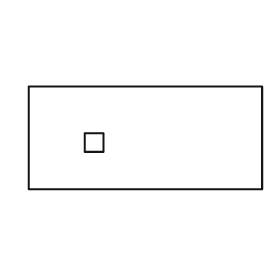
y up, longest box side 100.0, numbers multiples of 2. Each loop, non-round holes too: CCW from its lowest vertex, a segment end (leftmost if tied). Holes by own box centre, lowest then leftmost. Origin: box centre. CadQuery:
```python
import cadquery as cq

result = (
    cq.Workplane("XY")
    .moveTo(-50.0, -22.0)
    .lineTo(50.0, -22.0)
    .lineTo(50.0, 22.0)
    .lineTo(-50.0, 22.0)
    .close()
    .moveTo(-26.0, -6.0)
    .lineTo(-18.0, -6.0)
    .lineTo(-18.0, 2.0)
    .lineTo(-26.0, 2.0)
    .close()
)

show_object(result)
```